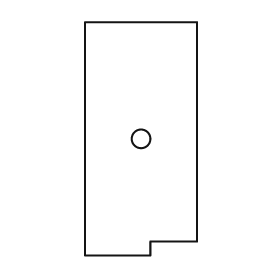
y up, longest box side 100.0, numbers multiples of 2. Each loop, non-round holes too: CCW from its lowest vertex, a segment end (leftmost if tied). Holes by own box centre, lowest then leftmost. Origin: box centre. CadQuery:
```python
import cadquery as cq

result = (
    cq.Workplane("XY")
    .moveTo(-24.0, -50.0)
    .lineTo(4.0, -50.0)
    .lineTo(4.0, -44.0)
    .lineTo(24.0, -44.0)
    .lineTo(24.0, 50.0)
    .lineTo(-24.0, 50.0)
    .close()
    .moveTo(0.0, 0.0)
    .circle(4.0)
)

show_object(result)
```